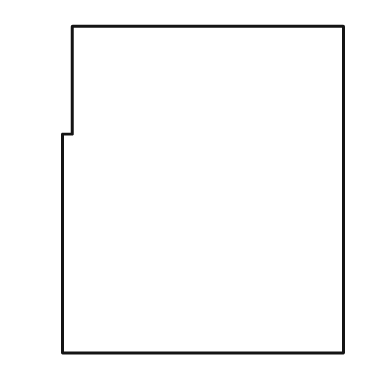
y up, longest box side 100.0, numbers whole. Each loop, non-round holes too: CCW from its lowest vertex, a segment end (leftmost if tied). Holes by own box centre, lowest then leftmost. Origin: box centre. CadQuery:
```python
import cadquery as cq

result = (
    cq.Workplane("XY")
    .moveTo(-43.0, -50.0)
    .lineTo(43.0, -50.0)
    .lineTo(43.0, 50.0)
    .lineTo(-40.0, 50.0)
    .lineTo(-40.0, 17.0)
    .lineTo(-43.0, 17.0)
    .close()
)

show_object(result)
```